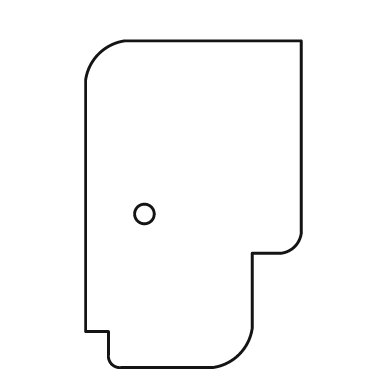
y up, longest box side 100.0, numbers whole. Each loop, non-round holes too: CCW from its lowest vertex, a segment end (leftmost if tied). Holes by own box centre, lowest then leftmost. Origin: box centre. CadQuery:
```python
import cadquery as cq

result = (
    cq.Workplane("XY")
    .moveTo(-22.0, -50.0)
    .lineTo(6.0, -50.0)
    .threePointArc((14.0, -46.0), (18.0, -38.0))
    .lineTo(18.0, -15.0)
    .lineTo(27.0, -15.0)
    .threePointArc((31.0, -13.0), (33.0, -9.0))
    .lineTo(33.0, 50.0)
    .lineTo(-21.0, 50.0)
    .threePointArc((-29.0, 46.0), (-33.0, 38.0))
    .lineTo(-33.0, -39.0)
    .lineTo(-26.0, -39.0)
    .lineTo(-26.0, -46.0)
    .threePointArc((-25.0, -49.0), (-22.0, -50.0))
    .close()
    .moveTo(-15.0, -3.0)
    .circle(3.0)
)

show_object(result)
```